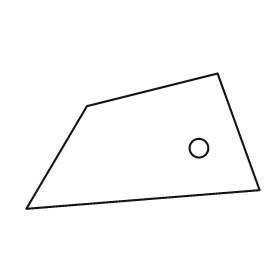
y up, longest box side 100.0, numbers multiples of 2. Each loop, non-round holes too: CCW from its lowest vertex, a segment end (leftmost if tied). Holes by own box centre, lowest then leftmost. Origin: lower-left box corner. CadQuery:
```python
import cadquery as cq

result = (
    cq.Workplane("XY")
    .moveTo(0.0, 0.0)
    .lineTo(100.0, 8.0)
    .lineTo(82.0, 58.0)
    .lineTo(26.0, 44.0)
    .close()
    .moveTo(74.0, 26.0)
    .circle(4.0)
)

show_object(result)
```